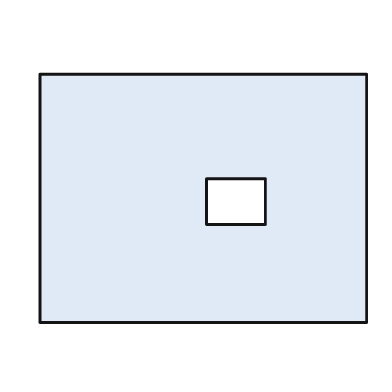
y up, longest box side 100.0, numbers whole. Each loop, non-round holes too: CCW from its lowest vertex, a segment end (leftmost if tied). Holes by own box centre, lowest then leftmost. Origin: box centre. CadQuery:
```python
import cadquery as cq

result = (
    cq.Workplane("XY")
    .moveTo(-50.0, -38.0)
    .lineTo(50.0, -38.0)
    .lineTo(50.0, 38.0)
    .lineTo(-50.0, 38.0)
    .close()
    .moveTo(1.0, -8.0)
    .lineTo(19.0, -8.0)
    .lineTo(19.0, 6.0)
    .lineTo(1.0, 6.0)
    .close()
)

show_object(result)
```